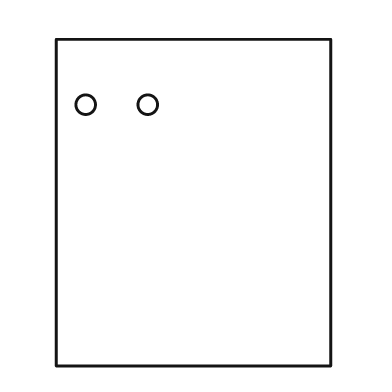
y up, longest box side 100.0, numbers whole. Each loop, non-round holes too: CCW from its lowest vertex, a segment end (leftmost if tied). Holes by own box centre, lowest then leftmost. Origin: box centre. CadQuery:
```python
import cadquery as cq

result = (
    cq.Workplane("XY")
    .moveTo(-42.0, -50.0)
    .lineTo(42.0, -50.0)
    .lineTo(42.0, 50.0)
    .lineTo(-42.0, 50.0)
    .close()
    .moveTo(-33.0, 30.0)
    .circle(3.0)
    .moveTo(-14.0, 30.0)
    .circle(3.0)
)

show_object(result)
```